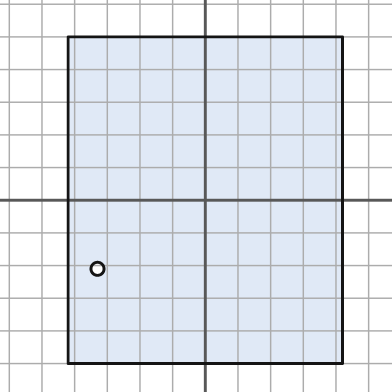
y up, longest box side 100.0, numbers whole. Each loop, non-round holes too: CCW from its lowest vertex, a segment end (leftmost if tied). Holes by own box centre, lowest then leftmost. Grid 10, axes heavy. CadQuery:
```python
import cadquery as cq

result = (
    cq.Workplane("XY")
    .moveTo(-42.0, -50.0)
    .lineTo(42.0, -50.0)
    .lineTo(42.0, 50.0)
    .lineTo(-42.0, 50.0)
    .close()
    .moveTo(-33.0, -21.0)
    .circle(2.0)
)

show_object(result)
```